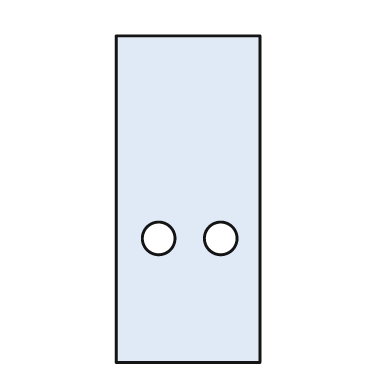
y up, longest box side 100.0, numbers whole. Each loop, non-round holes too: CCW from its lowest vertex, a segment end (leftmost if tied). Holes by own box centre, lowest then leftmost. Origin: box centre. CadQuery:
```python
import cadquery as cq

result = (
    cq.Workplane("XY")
    .moveTo(-22.0, -50.0)
    .lineTo(22.0, -50.0)
    .lineTo(22.0, 50.0)
    .lineTo(-22.0, 50.0)
    .close()
    .moveTo(-9.0, -12.0)
    .circle(5.0)
    .moveTo(10.0, -12.0)
    .circle(5.0)
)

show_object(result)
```